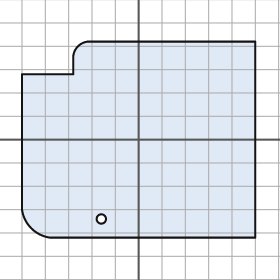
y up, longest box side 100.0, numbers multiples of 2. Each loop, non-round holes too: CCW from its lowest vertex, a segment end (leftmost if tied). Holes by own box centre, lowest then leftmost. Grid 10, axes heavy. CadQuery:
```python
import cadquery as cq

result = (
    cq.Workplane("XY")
    .moveTo(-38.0, -42.0)
    .lineTo(50.0, -42.0)
    .lineTo(50.0, 42.0)
    .lineTo(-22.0, 42.0)
    .threePointArc((-26.0, 40.0), (-28.0, 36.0))
    .lineTo(-28.0, 28.0)
    .lineTo(-50.0, 28.0)
    .lineTo(-50.0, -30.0)
    .threePointArc((-46.0, -38.0), (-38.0, -42.0))
    .close()
    .moveTo(-16.0, -34.0)
    .circle(2.0)
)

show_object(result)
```